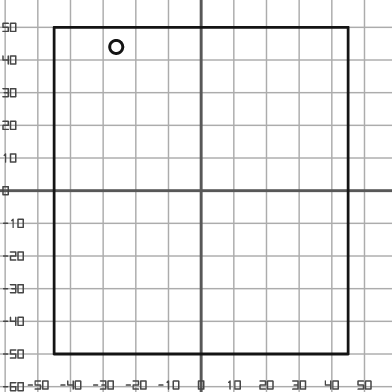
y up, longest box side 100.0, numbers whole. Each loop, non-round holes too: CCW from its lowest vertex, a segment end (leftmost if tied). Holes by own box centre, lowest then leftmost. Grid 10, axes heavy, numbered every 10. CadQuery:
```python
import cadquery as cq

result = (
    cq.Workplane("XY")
    .moveTo(-45.0, -50.0)
    .lineTo(45.0, -50.0)
    .lineTo(45.0, 50.0)
    .lineTo(-45.0, 50.0)
    .close()
    .moveTo(-26.0, 44.0)
    .circle(2.0)
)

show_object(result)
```